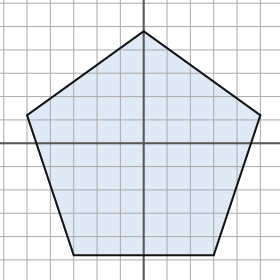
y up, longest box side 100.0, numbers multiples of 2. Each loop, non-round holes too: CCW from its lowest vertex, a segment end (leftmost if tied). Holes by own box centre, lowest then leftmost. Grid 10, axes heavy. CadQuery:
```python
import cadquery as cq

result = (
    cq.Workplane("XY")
    .moveTo(-30.0, -48.0)
    .lineTo(30.0, -48.0)
    .lineTo(50.0, 12.0)
    .lineTo(0.0, 48.0)
    .lineTo(-50.0, 12.0)
    .close()
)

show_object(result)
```